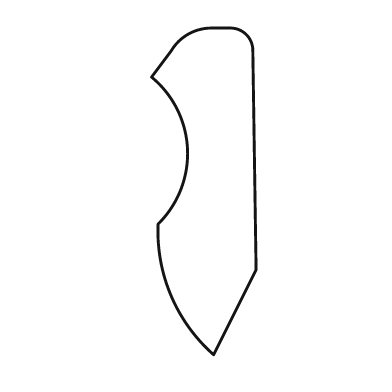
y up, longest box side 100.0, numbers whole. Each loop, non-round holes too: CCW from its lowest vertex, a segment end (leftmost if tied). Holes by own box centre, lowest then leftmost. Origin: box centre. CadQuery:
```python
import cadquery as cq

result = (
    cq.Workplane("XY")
    .moveTo(3.0, -50.0)
    .lineTo(16.0, -24.0)
    .lineTo(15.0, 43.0)
    .threePointArc((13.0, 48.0), (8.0, 50.0))
    .lineTo(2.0, 50.0)
    .threePointArc((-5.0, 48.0), (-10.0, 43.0))
    .lineTo(-16.0, 35.0)
    .threePointArc((-5.0, 13.0), (-14.0, -10.0))
    .threePointArc((-10.0, -32.0), (3.0, -50.0))
    .close()
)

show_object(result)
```